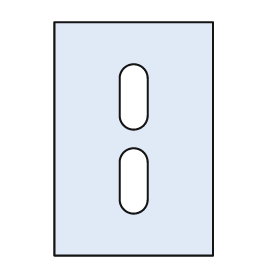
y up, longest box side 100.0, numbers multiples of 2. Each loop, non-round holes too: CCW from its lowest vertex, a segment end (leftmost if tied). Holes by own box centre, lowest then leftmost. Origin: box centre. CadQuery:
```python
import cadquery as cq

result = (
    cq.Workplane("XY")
    .moveTo(-34.0, -50.0)
    .lineTo(34.0, -50.0)
    .lineTo(34.0, 50.0)
    .lineTo(-34.0, 50.0)
    .close()
    .moveTo(-6.0, -26.0)
    .threePointArc((0.0, -32.0), (6.0, -26.0))
    .lineTo(6.0, -10.0)
    .threePointArc((0.0, -4.0), (-6.0, -10.0))
    .close()
    .moveTo(-6.0, 10.0)
    .threePointArc((0.0, 4.0), (6.0, 10.0))
    .lineTo(6.0, 26.0)
    .threePointArc((0.0, 32.0), (-6.0, 26.0))
    .close()
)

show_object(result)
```